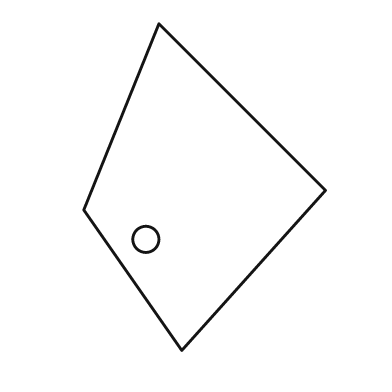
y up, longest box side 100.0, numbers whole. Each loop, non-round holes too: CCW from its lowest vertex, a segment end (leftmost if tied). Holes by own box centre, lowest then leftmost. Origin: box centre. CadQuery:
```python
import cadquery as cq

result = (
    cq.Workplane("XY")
    .moveTo(-7.0, -50.0)
    .lineTo(37.0, -1.0)
    .lineTo(-14.0, 50.0)
    .lineTo(-37.0, -7.0)
    .close()
    .moveTo(-18.0, -16.0)
    .circle(4.0)
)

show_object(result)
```